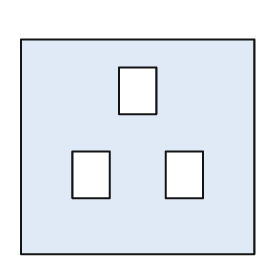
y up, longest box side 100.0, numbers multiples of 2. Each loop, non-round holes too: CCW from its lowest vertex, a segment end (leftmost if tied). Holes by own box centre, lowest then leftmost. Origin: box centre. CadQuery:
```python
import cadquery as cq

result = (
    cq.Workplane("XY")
    .moveTo(-50.0, -46.0)
    .lineTo(50.0, -46.0)
    .lineTo(50.0, 46.0)
    .lineTo(-50.0, 46.0)
    .close()
    .moveTo(-28.0, -22.0)
    .lineTo(-12.0, -22.0)
    .lineTo(-12.0, -2.0)
    .lineTo(-28.0, -2.0)
    .close()
    .moveTo(12.0, -22.0)
    .lineTo(28.0, -22.0)
    .lineTo(28.0, -2.0)
    .lineTo(12.0, -2.0)
    .close()
    .moveTo(-8.0, 14.0)
    .lineTo(8.0, 14.0)
    .lineTo(8.0, 34.0)
    .lineTo(-8.0, 34.0)
    .close()
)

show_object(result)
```